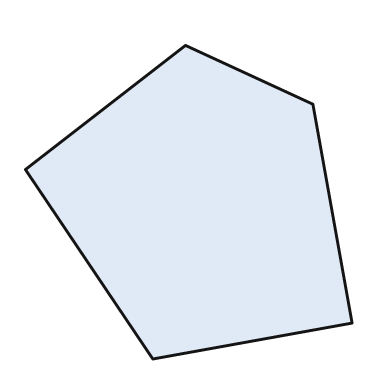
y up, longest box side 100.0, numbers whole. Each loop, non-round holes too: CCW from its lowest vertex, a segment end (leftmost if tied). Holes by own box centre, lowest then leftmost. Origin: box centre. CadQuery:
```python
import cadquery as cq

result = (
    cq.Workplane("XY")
    .moveTo(-11.0, -48.0)
    .lineTo(50.0, -37.0)
    .lineTo(38.0, 30.0)
    .lineTo(-1.0, 48.0)
    .lineTo(-50.0, 10.0)
    .close()
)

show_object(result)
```